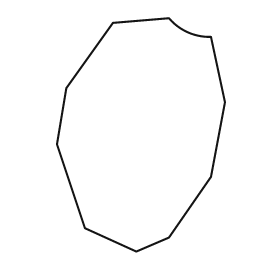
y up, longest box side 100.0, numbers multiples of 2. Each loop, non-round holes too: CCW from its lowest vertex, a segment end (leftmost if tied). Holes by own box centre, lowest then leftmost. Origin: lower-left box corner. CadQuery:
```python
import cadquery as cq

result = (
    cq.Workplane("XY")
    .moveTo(34.0, 0.0)
    .lineTo(48.0, 6.0)
    .lineTo(66.0, 32.0)
    .lineTo(72.0, 64.0)
    .lineTo(66.0, 92.0)
    .threePointArc((56.0, 94.0), (48.0, 100.0))
    .lineTo(24.0, 98.0)
    .lineTo(4.0, 70.0)
    .lineTo(0.0, 46.0)
    .lineTo(12.0, 10.0)
    .close()
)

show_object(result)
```